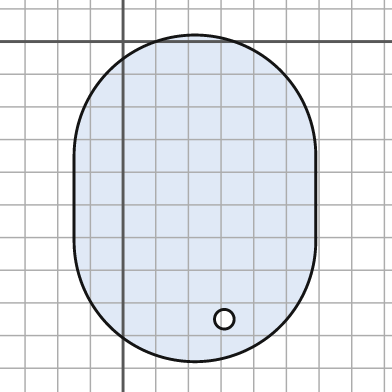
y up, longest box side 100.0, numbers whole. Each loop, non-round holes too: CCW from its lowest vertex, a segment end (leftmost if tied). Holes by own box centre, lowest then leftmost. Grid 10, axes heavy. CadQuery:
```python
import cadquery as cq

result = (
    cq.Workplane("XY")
    .moveTo(-15.0, -61.0)
    .threePointArc((22.0, -98.0), (59.0, -61.0))
    .lineTo(59.0, -35.0)
    .threePointArc((22.0, 2.0), (-15.0, -35.0))
    .close()
    .moveTo(31.0, -85.0)
    .circle(3.0)
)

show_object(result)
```